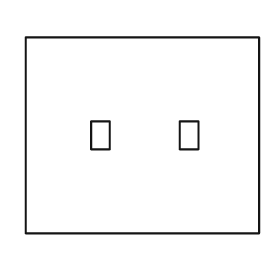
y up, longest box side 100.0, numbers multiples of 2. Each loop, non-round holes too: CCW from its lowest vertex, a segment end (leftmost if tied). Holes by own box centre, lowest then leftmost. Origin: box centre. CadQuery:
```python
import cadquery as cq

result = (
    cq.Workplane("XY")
    .moveTo(-50.0, -42.0)
    .lineTo(50.0, -42.0)
    .lineTo(50.0, 42.0)
    .lineTo(-50.0, 42.0)
    .close()
    .moveTo(-22.0, -6.0)
    .lineTo(-14.0, -6.0)
    .lineTo(-14.0, 6.0)
    .lineTo(-22.0, 6.0)
    .close()
    .moveTo(16.0, -6.0)
    .lineTo(24.0, -6.0)
    .lineTo(24.0, 6.0)
    .lineTo(16.0, 6.0)
    .close()
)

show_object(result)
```